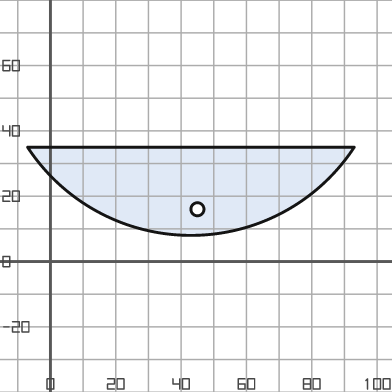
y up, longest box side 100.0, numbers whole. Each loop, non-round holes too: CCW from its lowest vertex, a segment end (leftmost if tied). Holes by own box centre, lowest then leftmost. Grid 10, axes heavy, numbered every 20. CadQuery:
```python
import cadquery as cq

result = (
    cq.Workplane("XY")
    .moveTo(-7.0, 35.0)
    .threePointArc((43.0, 8.0), (93.0, 35.0))
    .close()
    .moveTo(45.0, 16.0)
    .circle(2.0)
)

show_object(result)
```